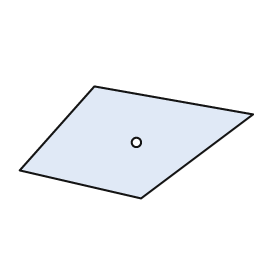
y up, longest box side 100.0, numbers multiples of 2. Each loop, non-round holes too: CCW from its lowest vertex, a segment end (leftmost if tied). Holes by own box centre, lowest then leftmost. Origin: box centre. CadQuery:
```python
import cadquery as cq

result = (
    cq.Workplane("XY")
    .moveTo(2.0, -24.0)
    .lineTo(50.0, 12.0)
    .lineTo(-18.0, 24.0)
    .lineTo(-50.0, -12.0)
    .close()
    .moveTo(0.0, 0.0)
    .circle(2.0)
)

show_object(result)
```